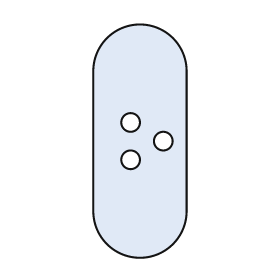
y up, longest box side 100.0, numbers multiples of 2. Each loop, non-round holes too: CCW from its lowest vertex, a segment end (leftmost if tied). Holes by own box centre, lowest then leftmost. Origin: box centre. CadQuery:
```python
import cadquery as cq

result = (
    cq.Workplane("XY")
    .moveTo(-20.0, -30.0)
    .threePointArc((0.0, -50.0), (20.0, -30.0))
    .lineTo(20.0, 30.0)
    .threePointArc((0.0, 50.0), (-20.0, 30.0))
    .close()
    .moveTo(-4.0, -8.0)
    .circle(4.0)
    .moveTo(10.0, 0.0)
    .circle(4.0)
    .moveTo(-4.0, 8.0)
    .circle(4.0)
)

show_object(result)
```